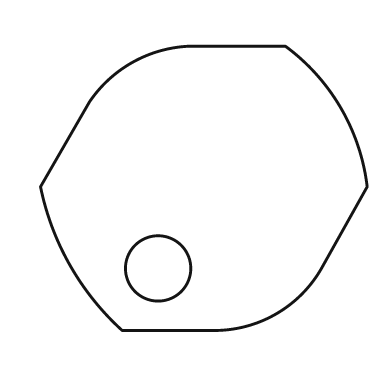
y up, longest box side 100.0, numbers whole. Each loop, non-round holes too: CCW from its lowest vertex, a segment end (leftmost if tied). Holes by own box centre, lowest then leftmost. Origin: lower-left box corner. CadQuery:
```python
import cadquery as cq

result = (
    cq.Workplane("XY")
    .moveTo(25.0, 0.0)
    .lineTo(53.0, 0.0)
    .threePointArc((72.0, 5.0), (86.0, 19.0))
    .lineTo(100.0, 44.0)
    .threePointArc((92.0, 68.0), (75.0, 87.0))
    .lineTo(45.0, 87.0)
    .threePointArc((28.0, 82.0), (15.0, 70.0))
    .lineTo(0.0, 44.0)
    .threePointArc((9.0, 20.0), (25.0, 0.0))
    .close()
    .moveTo(36.0, 19.0)
    .circle(10.0)
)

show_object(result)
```